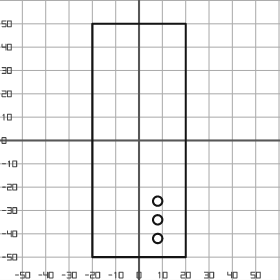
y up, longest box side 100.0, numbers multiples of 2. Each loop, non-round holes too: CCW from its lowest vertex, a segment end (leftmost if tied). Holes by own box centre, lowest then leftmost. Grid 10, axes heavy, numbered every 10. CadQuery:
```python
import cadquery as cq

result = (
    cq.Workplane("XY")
    .moveTo(-20.0, -50.0)
    .lineTo(20.0, -50.0)
    .lineTo(20.0, 50.0)
    .lineTo(-20.0, 50.0)
    .close()
    .moveTo(8.0, -42.0)
    .circle(2.0)
    .moveTo(8.0, -34.0)
    .circle(2.0)
    .moveTo(8.0, -26.0)
    .circle(2.0)
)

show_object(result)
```